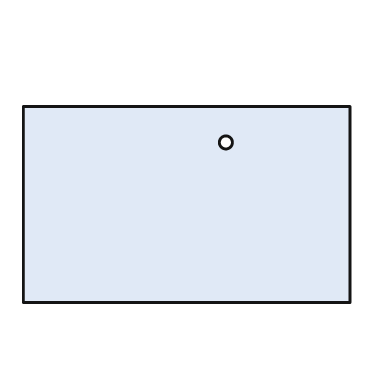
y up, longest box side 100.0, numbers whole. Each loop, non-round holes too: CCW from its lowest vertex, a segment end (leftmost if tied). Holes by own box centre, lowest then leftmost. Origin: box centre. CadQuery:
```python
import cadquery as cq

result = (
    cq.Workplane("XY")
    .moveTo(-50.0, -30.0)
    .lineTo(50.0, -30.0)
    .lineTo(50.0, 30.0)
    .lineTo(-50.0, 30.0)
    .close()
    .moveTo(12.0, 19.0)
    .circle(2.0)
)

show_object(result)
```